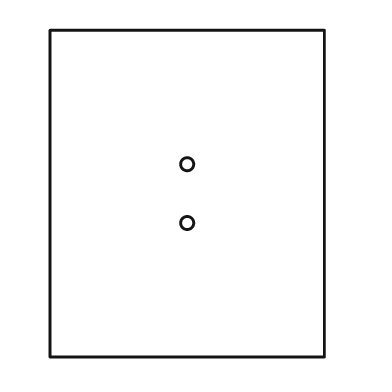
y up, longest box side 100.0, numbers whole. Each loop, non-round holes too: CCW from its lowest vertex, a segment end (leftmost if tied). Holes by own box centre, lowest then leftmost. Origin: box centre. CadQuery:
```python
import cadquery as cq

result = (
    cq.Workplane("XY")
    .moveTo(-42.0, -50.0)
    .lineTo(42.0, -50.0)
    .lineTo(42.0, 50.0)
    .lineTo(-42.0, 50.0)
    .close()
    .moveTo(0.0, -9.0)
    .circle(2.0)
    .moveTo(0.0, 9.0)
    .circle(2.0)
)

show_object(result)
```